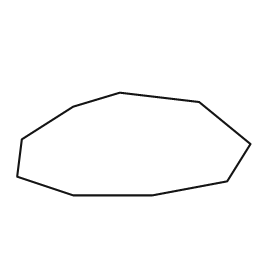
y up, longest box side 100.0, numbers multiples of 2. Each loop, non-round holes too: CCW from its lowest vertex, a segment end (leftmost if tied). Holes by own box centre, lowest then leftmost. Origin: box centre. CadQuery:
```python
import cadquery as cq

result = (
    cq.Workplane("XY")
    .moveTo(-26.0, -22.0)
    .lineTo(8.0, -22.0)
    .lineTo(40.0, -16.0)
    .lineTo(50.0, 0.0)
    .lineTo(28.0, 18.0)
    .lineTo(-6.0, 22.0)
    .lineTo(-26.0, 16.0)
    .lineTo(-48.0, 2.0)
    .lineTo(-50.0, -14.0)
    .close()
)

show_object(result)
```